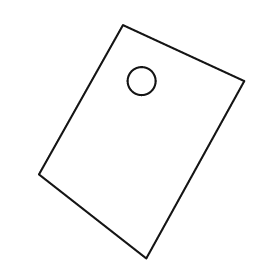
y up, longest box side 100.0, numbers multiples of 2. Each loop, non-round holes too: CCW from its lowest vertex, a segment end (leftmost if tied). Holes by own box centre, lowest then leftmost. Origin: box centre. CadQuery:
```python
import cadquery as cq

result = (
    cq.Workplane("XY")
    .moveTo(2.0, -50.0)
    .lineTo(44.0, 26.0)
    .lineTo(-8.0, 50.0)
    .lineTo(-44.0, -14.0)
    .close()
    .moveTo(0.0, 26.0)
    .circle(6.0)
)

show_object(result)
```